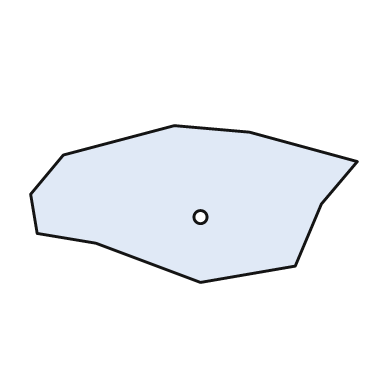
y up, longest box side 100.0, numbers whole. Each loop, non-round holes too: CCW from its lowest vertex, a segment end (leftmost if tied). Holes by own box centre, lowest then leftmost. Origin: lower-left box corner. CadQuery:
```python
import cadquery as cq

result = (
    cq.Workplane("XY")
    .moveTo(52.0, 0.0)
    .lineTo(81.0, 5.0)
    .lineTo(89.0, 24.0)
    .lineTo(100.0, 37.0)
    .lineTo(67.0, 46.0)
    .lineTo(44.0, 48.0)
    .lineTo(10.0, 39.0)
    .lineTo(0.0, 27.0)
    .lineTo(2.0, 15.0)
    .lineTo(20.0, 12.0)
    .close()
    .moveTo(52.0, 20.0)
    .circle(2.0)
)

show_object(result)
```